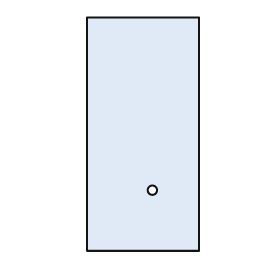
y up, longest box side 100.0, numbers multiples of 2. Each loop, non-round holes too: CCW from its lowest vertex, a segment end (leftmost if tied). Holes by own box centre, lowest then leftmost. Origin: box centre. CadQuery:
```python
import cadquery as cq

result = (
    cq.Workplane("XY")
    .moveTo(-24.0, -50.0)
    .lineTo(24.0, -50.0)
    .lineTo(24.0, 50.0)
    .lineTo(-24.0, 50.0)
    .close()
    .moveTo(4.0, -24.0)
    .circle(2.0)
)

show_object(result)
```